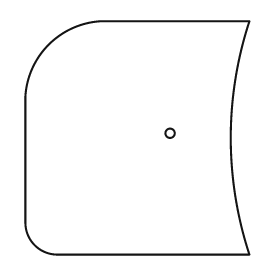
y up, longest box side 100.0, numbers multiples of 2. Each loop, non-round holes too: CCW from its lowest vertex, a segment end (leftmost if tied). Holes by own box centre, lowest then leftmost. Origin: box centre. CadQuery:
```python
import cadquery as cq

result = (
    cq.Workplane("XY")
    .moveTo(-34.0, -50.0)
    .lineTo(48.0, -50.0)
    .threePointArc((40.0, 0.0), (48.0, 50.0))
    .lineTo(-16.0, 50.0)
    .threePointArc((-38.0, 40.0), (-48.0, 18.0))
    .lineTo(-48.0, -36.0)
    .threePointArc((-44.0, -46.0), (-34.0, -50.0))
    .close()
    .moveTo(14.0, 2.0)
    .circle(2.0)
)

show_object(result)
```